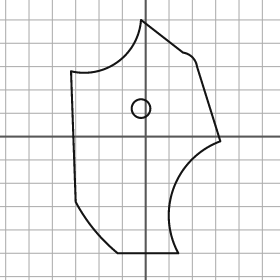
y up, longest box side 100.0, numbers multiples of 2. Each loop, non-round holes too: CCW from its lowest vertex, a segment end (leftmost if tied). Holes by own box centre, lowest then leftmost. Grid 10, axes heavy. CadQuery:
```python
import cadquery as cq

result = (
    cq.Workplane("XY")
    .moveTo(-12.0, -50.0)
    .lineTo(14.0, -50.0)
    .threePointArc((12.0, -22.0), (32.0, -2.0))
    .lineTo(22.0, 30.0)
    .threePointArc((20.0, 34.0), (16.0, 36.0))
    .lineTo(-2.0, 50.0)
    .threePointArc((-12.0, 32.0), (-32.0, 28.0))
    .lineTo(-30.0, -28.0)
    .threePointArc((-22.0, -40.0), (-12.0, -50.0))
    .close()
    .moveTo(-2.0, 12.0)
    .circle(4.0)
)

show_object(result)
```